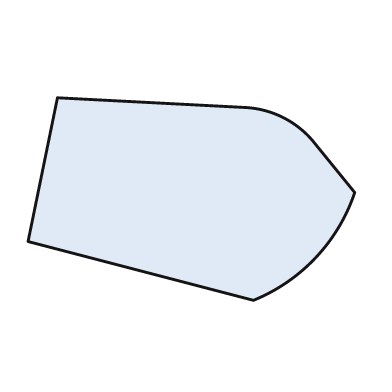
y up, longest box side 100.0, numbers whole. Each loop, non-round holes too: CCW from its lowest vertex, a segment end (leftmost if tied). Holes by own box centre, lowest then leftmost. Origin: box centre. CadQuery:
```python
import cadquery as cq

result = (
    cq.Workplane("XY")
    .moveTo(19.0, -31.0)
    .threePointArc((38.0, -18.0), (50.0, 2.0))
    .lineTo(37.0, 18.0)
    .threePointArc((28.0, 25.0), (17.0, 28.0))
    .lineTo(-41.0, 31.0)
    .lineTo(-50.0, -13.0)
    .close()
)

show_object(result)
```